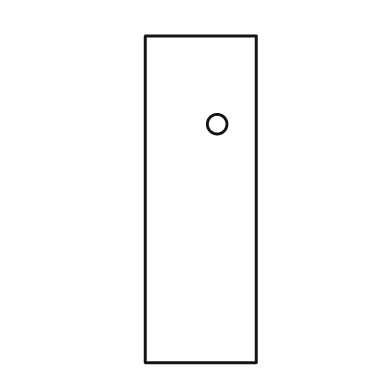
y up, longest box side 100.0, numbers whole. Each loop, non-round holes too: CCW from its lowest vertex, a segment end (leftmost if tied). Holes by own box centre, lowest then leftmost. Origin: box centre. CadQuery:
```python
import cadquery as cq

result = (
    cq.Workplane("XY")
    .moveTo(-17.0, -50.0)
    .lineTo(17.0, -50.0)
    .lineTo(17.0, 50.0)
    .lineTo(-17.0, 50.0)
    .close()
    .moveTo(5.0, 23.0)
    .circle(3.0)
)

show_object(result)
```